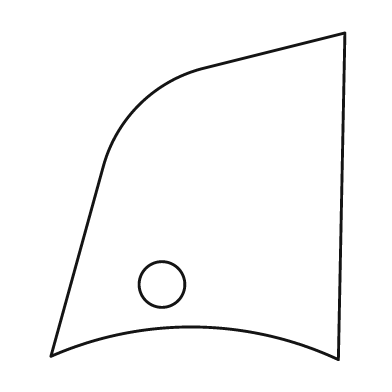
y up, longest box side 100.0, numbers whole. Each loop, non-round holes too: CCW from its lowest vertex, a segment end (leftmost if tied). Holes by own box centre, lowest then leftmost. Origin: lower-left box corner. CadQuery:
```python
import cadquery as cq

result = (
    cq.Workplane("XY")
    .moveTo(88.0, 0.0)
    .lineTo(90.0, 100.0)
    .lineTo(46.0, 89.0)
    .threePointArc((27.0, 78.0), (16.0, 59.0))
    .lineTo(0.0, 1.0)
    .threePointArc((44.0, 10.0), (88.0, 0.0))
    .close()
    .moveTo(34.0, 23.0)
    .circle(7.0)
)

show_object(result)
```